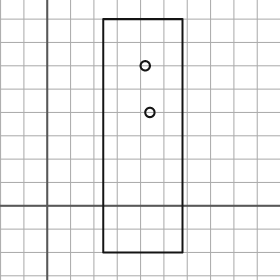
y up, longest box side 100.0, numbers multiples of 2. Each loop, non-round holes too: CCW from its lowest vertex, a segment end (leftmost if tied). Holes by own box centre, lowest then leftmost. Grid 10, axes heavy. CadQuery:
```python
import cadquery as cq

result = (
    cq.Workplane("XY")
    .moveTo(24.0, -20.0)
    .lineTo(58.0, -20.0)
    .lineTo(58.0, 80.0)
    .lineTo(24.0, 80.0)
    .close()
    .moveTo(44.0, 40.0)
    .circle(2.0)
    .moveTo(42.0, 60.0)
    .circle(2.0)
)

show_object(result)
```